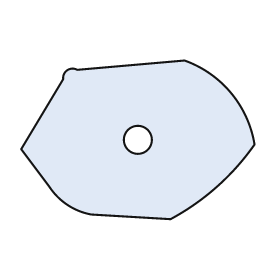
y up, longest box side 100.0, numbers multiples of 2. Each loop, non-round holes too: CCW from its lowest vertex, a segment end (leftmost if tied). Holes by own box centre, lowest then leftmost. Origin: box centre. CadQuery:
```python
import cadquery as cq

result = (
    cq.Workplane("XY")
    .moveTo(14.0, -34.0)
    .threePointArc((34.0, -20.0), (50.0, -2.0))
    .threePointArc((40.0, 20.0), (20.0, 34.0))
    .lineTo(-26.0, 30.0)
    .threePointArc((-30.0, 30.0), (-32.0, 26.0))
    .lineTo(-50.0, -4.0)
    .lineTo(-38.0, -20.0)
    .threePointArc((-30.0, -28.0), (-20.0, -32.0))
    .close()
    .moveTo(0.0, 0.0)
    .circle(6.0)
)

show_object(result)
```